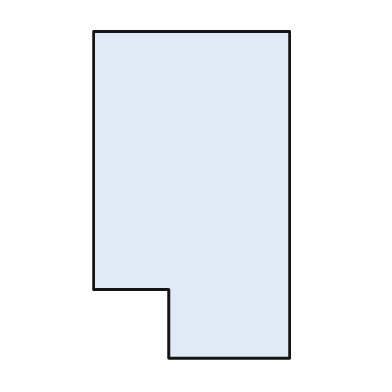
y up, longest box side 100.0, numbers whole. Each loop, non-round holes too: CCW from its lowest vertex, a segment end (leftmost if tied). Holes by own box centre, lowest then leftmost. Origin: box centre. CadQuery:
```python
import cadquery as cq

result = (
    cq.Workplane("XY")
    .moveTo(-7.0, -50.0)
    .lineTo(30.0, -50.0)
    .lineTo(30.0, 50.0)
    .lineTo(-30.0, 50.0)
    .lineTo(-30.0, -29.0)
    .lineTo(-7.0, -29.0)
    .close()
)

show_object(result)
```